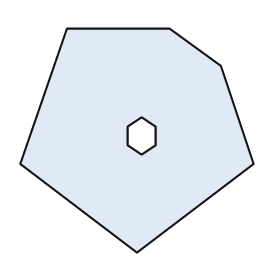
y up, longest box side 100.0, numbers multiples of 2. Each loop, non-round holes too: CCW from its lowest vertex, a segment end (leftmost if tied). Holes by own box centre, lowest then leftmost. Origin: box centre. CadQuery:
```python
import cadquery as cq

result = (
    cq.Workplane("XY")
    .moveTo(0.0, -48.0)
    .lineTo(50.0, -10.0)
    .lineTo(36.0, 32.0)
    .lineTo(14.0, 48.0)
    .lineTo(-30.0, 48.0)
    .lineTo(-50.0, -10.0)
    .close()
    .moveTo(2.0, -6.0)
    .lineTo(8.0, -2.0)
    .lineTo(8.0, 6.0)
    .lineTo(2.0, 10.0)
    .lineTo(-4.0, 6.0)
    .lineTo(-4.0, -2.0)
    .close()
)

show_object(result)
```